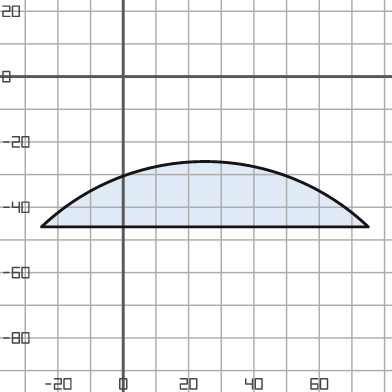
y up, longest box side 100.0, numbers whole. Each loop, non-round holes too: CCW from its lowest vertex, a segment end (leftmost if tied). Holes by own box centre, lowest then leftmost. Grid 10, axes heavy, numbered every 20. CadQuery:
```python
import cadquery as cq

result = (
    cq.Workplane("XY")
    .moveTo(-25.0, -46.0)
    .lineTo(75.0, -46.0)
    .threePointArc((25.0, -26.0), (-25.0, -46.0))
    .close()
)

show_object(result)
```